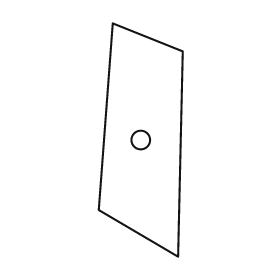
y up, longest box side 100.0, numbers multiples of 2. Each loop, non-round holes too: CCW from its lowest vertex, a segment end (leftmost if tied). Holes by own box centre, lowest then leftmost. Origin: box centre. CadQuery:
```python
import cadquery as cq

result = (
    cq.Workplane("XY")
    .moveTo(16.0, -50.0)
    .lineTo(18.0, 38.0)
    .lineTo(-12.0, 50.0)
    .lineTo(-18.0, -30.0)
    .close()
    .moveTo(0.0, 0.0)
    .circle(4.0)
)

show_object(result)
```